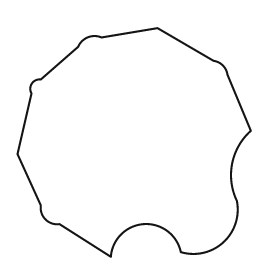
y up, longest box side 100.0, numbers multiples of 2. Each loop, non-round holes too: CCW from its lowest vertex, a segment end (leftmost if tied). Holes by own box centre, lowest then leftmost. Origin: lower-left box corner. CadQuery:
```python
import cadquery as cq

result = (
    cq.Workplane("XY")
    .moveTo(40.0, 0.0)
    .threePointArc((54.0, 14.0), (70.0, 2.0))
    .threePointArc((88.0, 6.0), (94.0, 24.0))
    .threePointArc((92.0, 40.0), (100.0, 54.0))
    .lineTo(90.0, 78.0)
    .threePointArc((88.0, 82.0), (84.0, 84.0))
    .lineTo(60.0, 98.0)
    .lineTo(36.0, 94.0)
    .threePointArc((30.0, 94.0), (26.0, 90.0))
    .lineTo(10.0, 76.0)
    .threePointArc((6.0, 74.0), (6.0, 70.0))
    .lineTo(0.0, 44.0)
    .lineTo(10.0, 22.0)
    .threePointArc((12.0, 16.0), (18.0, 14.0))
    .close()
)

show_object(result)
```